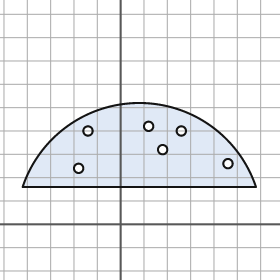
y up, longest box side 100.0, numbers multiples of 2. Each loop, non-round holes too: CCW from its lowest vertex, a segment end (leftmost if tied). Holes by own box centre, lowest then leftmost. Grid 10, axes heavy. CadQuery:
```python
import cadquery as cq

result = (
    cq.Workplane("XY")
    .moveTo(-42.0, 16.0)
    .lineTo(58.0, 16.0)
    .threePointArc((8.0, 52.0), (-42.0, 16.0))
    .close()
    .moveTo(-18.0, 24.0)
    .circle(2.0)
    .moveTo(46.0, 26.0)
    .circle(2.0)
    .moveTo(18.0, 32.0)
    .circle(2.0)
    .moveTo(-14.0, 40.0)
    .circle(2.0)
    .moveTo(26.0, 40.0)
    .circle(2.0)
    .moveTo(12.0, 42.0)
    .circle(2.0)
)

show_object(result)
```